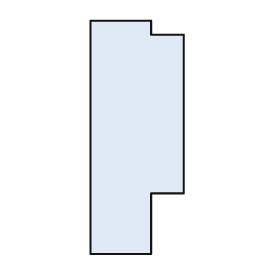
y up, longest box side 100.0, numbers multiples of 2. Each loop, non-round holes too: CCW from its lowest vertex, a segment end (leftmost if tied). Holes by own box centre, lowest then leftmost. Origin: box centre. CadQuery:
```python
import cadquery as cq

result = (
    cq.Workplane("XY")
    .moveTo(-20.0, -50.0)
    .lineTo(6.0, -50.0)
    .lineTo(6.0, -24.0)
    .lineTo(20.0, -24.0)
    .lineTo(20.0, 44.0)
    .lineTo(6.0, 44.0)
    .lineTo(6.0, 50.0)
    .lineTo(-20.0, 50.0)
    .close()
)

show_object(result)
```